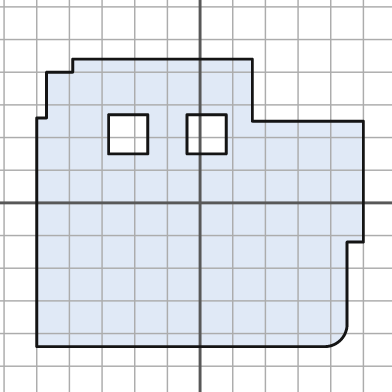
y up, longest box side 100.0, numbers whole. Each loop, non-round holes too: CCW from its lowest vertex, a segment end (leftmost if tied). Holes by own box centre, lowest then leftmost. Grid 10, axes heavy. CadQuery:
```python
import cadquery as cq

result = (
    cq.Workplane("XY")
    .moveTo(-50.0, -44.0)
    .lineTo(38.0, -44.0)
    .threePointArc((43.0, -42.0), (45.0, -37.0))
    .lineTo(45.0, -12.0)
    .lineTo(50.0, -12.0)
    .lineTo(50.0, 25.0)
    .lineTo(16.0, 25.0)
    .lineTo(16.0, 44.0)
    .lineTo(-39.0, 44.0)
    .lineTo(-39.0, 40.0)
    .lineTo(-47.0, 40.0)
    .lineTo(-47.0, 26.0)
    .lineTo(-50.0, 26.0)
    .close()
    .moveTo(-28.0, 15.0)
    .lineTo(-16.0, 15.0)
    .lineTo(-16.0, 27.0)
    .lineTo(-28.0, 27.0)
    .close()
    .moveTo(-4.0, 15.0)
    .lineTo(8.0, 15.0)
    .lineTo(8.0, 27.0)
    .lineTo(-4.0, 27.0)
    .close()
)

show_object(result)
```